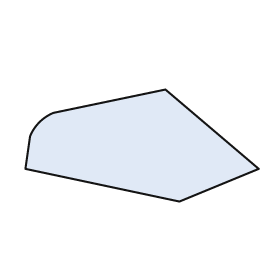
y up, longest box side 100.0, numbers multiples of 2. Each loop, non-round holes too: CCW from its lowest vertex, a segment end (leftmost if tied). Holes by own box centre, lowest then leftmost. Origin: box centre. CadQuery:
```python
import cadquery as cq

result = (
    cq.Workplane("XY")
    .moveTo(16.0, -24.0)
    .lineTo(50.0, -10.0)
    .lineTo(10.0, 24.0)
    .lineTo(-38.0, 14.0)
    .threePointArc((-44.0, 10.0), (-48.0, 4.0))
    .lineTo(-50.0, -10.0)
    .close()
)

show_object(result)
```